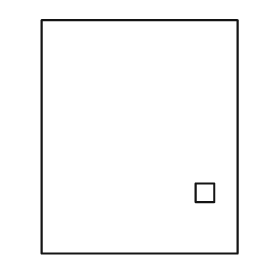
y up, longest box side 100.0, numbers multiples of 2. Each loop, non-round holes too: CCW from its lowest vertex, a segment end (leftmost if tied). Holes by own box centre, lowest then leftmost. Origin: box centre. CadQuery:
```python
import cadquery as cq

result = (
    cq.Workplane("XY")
    .moveTo(-42.0, -50.0)
    .lineTo(42.0, -50.0)
    .lineTo(42.0, 50.0)
    .lineTo(-42.0, 50.0)
    .close()
    .moveTo(24.0, -28.0)
    .lineTo(32.0, -28.0)
    .lineTo(32.0, -20.0)
    .lineTo(24.0, -20.0)
    .close()
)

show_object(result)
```